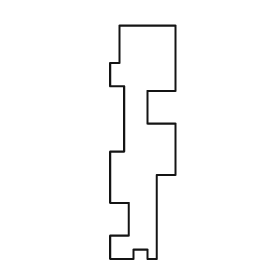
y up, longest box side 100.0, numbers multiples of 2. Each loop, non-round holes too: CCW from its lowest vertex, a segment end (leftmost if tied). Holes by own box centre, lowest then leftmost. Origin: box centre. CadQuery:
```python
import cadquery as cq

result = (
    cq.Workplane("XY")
    .moveTo(-14.0, -50.0)
    .lineTo(-4.0, -50.0)
    .lineTo(-4.0, -46.0)
    .lineTo(2.0, -46.0)
    .lineTo(2.0, -50.0)
    .lineTo(6.0, -50.0)
    .lineTo(6.0, -14.0)
    .lineTo(14.0, -14.0)
    .lineTo(14.0, 8.0)
    .lineTo(2.0, 8.0)
    .lineTo(2.0, 22.0)
    .lineTo(14.0, 22.0)
    .lineTo(14.0, 50.0)
    .lineTo(-10.0, 50.0)
    .lineTo(-10.0, 34.0)
    .lineTo(-14.0, 34.0)
    .lineTo(-14.0, 24.0)
    .lineTo(-8.0, 24.0)
    .lineTo(-8.0, -4.0)
    .lineTo(-14.0, -4.0)
    .lineTo(-14.0, -26.0)
    .lineTo(-6.0, -26.0)
    .lineTo(-6.0, -40.0)
    .lineTo(-14.0, -40.0)
    .close()
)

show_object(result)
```